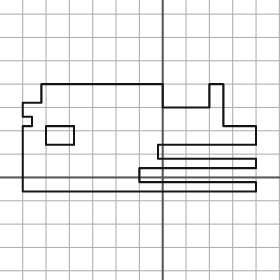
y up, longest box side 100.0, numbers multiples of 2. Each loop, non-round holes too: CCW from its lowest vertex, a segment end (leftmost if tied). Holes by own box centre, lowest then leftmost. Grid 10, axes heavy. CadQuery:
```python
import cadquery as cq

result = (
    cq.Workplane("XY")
    .moveTo(-60.0, -6.0)
    .lineTo(40.0, -6.0)
    .lineTo(40.0, -2.0)
    .lineTo(-10.0, -2.0)
    .lineTo(-10.0, 4.0)
    .lineTo(40.0, 4.0)
    .lineTo(40.0, 8.0)
    .lineTo(-2.0, 8.0)
    .lineTo(-2.0, 14.0)
    .lineTo(40.0, 14.0)
    .lineTo(40.0, 22.0)
    .lineTo(26.0, 22.0)
    .lineTo(26.0, 40.0)
    .lineTo(20.0, 40.0)
    .lineTo(20.0, 30.0)
    .lineTo(0.0, 30.0)
    .lineTo(0.0, 40.0)
    .lineTo(-52.0, 40.0)
    .lineTo(-52.0, 32.0)
    .lineTo(-60.0, 32.0)
    .lineTo(-60.0, 26.0)
    .lineTo(-56.0, 26.0)
    .lineTo(-56.0, 22.0)
    .lineTo(-60.0, 22.0)
    .close()
    .moveTo(-50.0, 14.0)
    .lineTo(-38.0, 14.0)
    .lineTo(-38.0, 22.0)
    .lineTo(-50.0, 22.0)
    .close()
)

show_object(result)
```